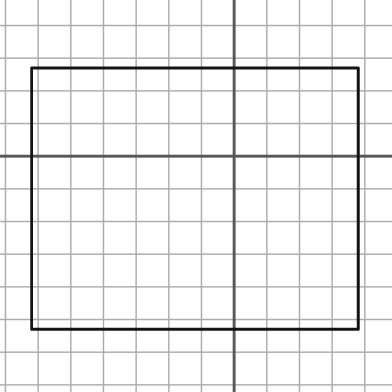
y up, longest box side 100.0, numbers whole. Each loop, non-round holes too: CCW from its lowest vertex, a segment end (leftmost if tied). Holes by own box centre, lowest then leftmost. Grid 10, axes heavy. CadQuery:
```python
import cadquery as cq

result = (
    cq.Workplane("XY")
    .moveTo(-62.0, -53.0)
    .lineTo(38.0, -53.0)
    .lineTo(38.0, 27.0)
    .lineTo(-62.0, 27.0)
    .close()
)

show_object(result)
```